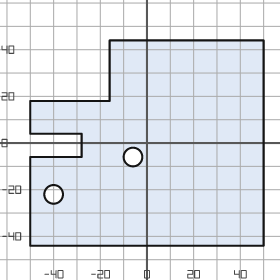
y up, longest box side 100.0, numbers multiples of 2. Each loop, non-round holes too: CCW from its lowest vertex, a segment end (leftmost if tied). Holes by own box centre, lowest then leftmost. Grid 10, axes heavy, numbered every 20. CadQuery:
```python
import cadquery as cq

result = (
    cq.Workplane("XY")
    .moveTo(-50.0, -44.0)
    .lineTo(50.0, -44.0)
    .lineTo(50.0, 44.0)
    .lineTo(-16.0, 44.0)
    .lineTo(-16.0, 18.0)
    .lineTo(-50.0, 18.0)
    .lineTo(-50.0, 4.0)
    .lineTo(-28.0, 4.0)
    .lineTo(-28.0, -6.0)
    .lineTo(-50.0, -6.0)
    .close()
    .moveTo(-40.0, -22.0)
    .circle(4.0)
    .moveTo(-6.0, -6.0)
    .circle(4.0)
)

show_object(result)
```